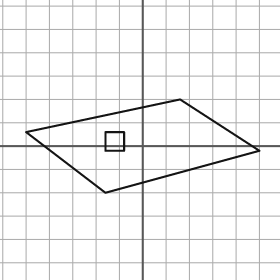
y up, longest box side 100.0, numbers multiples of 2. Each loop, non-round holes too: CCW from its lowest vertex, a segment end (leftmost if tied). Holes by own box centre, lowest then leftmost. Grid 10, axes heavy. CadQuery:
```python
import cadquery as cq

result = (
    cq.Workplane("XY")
    .moveTo(-16.0, -20.0)
    .lineTo(50.0, -2.0)
    .lineTo(16.0, 20.0)
    .lineTo(-50.0, 6.0)
    .close()
    .moveTo(-16.0, -2.0)
    .lineTo(-8.0, -2.0)
    .lineTo(-8.0, 6.0)
    .lineTo(-16.0, 6.0)
    .close()
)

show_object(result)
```